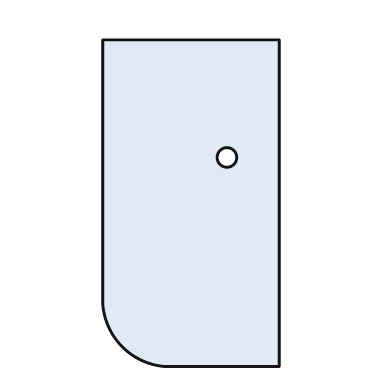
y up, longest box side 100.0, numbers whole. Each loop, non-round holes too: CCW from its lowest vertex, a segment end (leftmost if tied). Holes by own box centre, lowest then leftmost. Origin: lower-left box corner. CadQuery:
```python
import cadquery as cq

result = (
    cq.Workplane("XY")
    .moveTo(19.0, 0.0)
    .lineTo(54.0, 0.0)
    .lineTo(54.0, 100.0)
    .lineTo(0.0, 100.0)
    .lineTo(0.0, 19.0)
    .threePointArc((6.0, 6.0), (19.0, 0.0))
    .close()
    .moveTo(38.0, 64.0)
    .circle(3.0)
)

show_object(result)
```